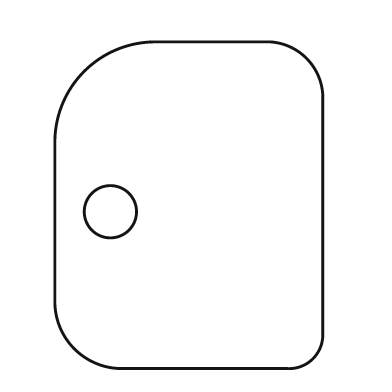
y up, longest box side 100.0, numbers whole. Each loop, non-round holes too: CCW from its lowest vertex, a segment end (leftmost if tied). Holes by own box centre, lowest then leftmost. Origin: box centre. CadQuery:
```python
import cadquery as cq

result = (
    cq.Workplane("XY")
    .moveTo(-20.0, -50.0)
    .lineTo(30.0, -50.0)
    .threePointArc((38.0, -47.0), (41.0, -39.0))
    .lineTo(41.0, 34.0)
    .threePointArc((36.0, 45.0), (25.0, 50.0))
    .lineTo(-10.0, 50.0)
    .threePointArc((-32.0, 41.0), (-41.0, 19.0))
    .lineTo(-41.0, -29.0)
    .threePointArc((-35.0, -44.0), (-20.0, -50.0))
    .close()
    .moveTo(-24.0, -2.0)
    .circle(8.0)
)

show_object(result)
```